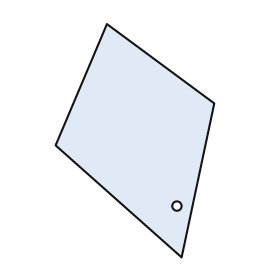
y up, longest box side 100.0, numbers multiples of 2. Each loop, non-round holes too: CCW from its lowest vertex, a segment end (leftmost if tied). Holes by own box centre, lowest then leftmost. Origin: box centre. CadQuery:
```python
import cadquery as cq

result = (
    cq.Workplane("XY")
    .moveTo(20.0, -50.0)
    .lineTo(34.0, 16.0)
    .lineTo(-12.0, 50.0)
    .lineTo(-34.0, -2.0)
    .close()
    .moveTo(18.0, -28.0)
    .circle(2.0)
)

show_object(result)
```